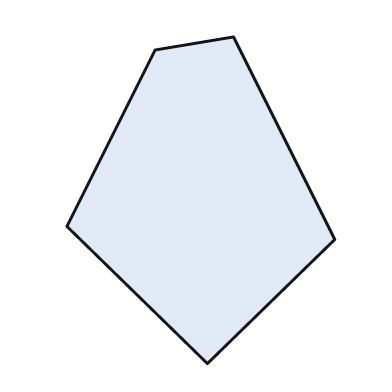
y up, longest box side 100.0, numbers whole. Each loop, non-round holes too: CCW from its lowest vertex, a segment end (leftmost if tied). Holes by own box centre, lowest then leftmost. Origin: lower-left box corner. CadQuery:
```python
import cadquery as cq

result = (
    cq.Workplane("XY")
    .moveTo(43.0, 0.0)
    .lineTo(82.0, 38.0)
    .lineTo(51.0, 100.0)
    .lineTo(27.0, 96.0)
    .lineTo(0.0, 42.0)
    .close()
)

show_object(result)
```